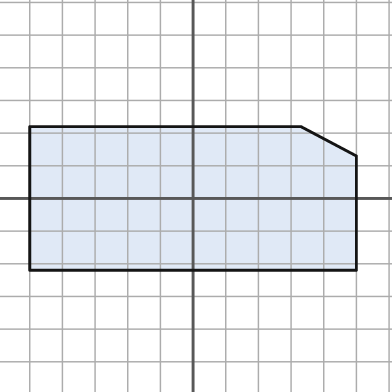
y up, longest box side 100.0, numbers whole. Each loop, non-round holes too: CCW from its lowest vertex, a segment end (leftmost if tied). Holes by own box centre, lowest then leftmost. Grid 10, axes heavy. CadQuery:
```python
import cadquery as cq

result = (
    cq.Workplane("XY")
    .moveTo(-50.0, -22.0)
    .lineTo(50.0, -22.0)
    .lineTo(50.0, 13.0)
    .lineTo(33.0, 22.0)
    .lineTo(-50.0, 22.0)
    .close()
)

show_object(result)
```